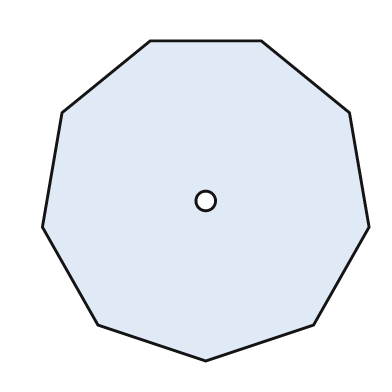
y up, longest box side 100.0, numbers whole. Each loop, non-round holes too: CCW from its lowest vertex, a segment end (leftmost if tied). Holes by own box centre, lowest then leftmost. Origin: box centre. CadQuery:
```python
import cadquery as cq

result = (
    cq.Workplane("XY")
    .moveTo(0.0, -49.0)
    .lineTo(33.0, -38.0)
    .lineTo(50.0, -8.0)
    .lineTo(44.0, 27.0)
    .lineTo(17.0, 49.0)
    .lineTo(-17.0, 49.0)
    .lineTo(-44.0, 27.0)
    .lineTo(-50.0, -8.0)
    .lineTo(-33.0, -38.0)
    .close()
    .moveTo(0.0, 0.0)
    .circle(3.0)
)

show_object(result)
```